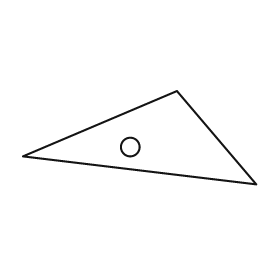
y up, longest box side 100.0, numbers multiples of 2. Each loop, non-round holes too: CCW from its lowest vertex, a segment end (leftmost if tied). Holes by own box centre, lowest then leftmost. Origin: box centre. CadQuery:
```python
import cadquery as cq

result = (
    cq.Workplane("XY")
    .moveTo(50.0, -20.0)
    .lineTo(16.0, 20.0)
    .lineTo(-50.0, -8.0)
    .close()
    .moveTo(-4.0, -4.0)
    .circle(4.0)
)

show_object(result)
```